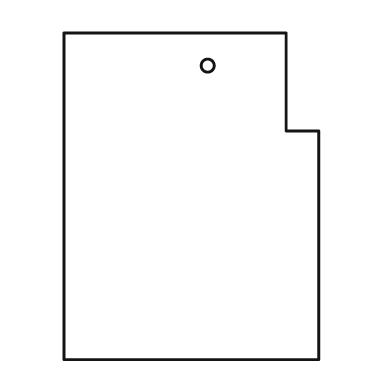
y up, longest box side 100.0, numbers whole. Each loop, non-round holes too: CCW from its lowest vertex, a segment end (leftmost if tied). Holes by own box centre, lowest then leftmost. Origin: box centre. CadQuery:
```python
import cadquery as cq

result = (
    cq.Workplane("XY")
    .moveTo(-39.0, -50.0)
    .lineTo(39.0, -50.0)
    .lineTo(39.0, 20.0)
    .lineTo(29.0, 20.0)
    .lineTo(29.0, 50.0)
    .lineTo(-39.0, 50.0)
    .close()
    .moveTo(5.0, 40.0)
    .circle(2.0)
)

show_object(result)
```